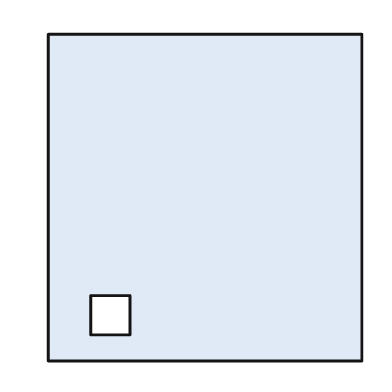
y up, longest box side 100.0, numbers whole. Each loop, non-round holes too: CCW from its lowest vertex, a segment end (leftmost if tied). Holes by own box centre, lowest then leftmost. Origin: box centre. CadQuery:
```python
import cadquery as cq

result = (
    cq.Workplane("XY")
    .moveTo(-48.0, -50.0)
    .lineTo(48.0, -50.0)
    .lineTo(48.0, 50.0)
    .lineTo(-48.0, 50.0)
    .close()
    .moveTo(-35.0, -42.0)
    .lineTo(-23.0, -42.0)
    .lineTo(-23.0, -30.0)
    .lineTo(-35.0, -30.0)
    .close()
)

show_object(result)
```